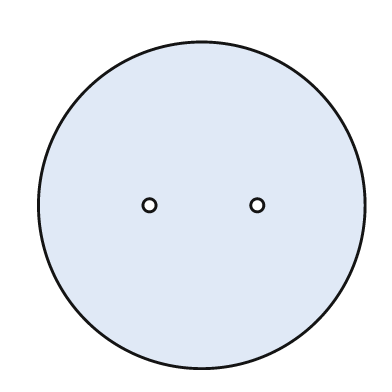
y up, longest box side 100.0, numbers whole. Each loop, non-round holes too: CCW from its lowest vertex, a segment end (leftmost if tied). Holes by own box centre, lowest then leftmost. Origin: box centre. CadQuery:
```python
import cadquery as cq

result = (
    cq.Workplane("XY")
    .moveTo(0.0, 0.0)
    .circle(50.0)
    .moveTo(-16.0, 0.0)
    .circle(2.0)
    .moveTo(17.0, 0.0)
    .circle(2.0)
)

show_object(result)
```